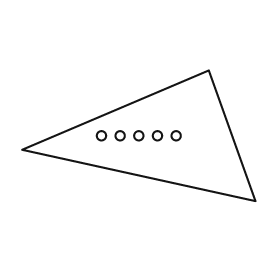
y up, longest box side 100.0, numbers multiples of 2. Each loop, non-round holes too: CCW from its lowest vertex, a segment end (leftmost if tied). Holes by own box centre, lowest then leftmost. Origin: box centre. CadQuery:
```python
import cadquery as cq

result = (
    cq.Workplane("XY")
    .moveTo(50.0, -28.0)
    .lineTo(30.0, 28.0)
    .lineTo(-50.0, -6.0)
    .close()
    .moveTo(-16.0, 0.0)
    .circle(2.0)
    .moveTo(-8.0, 0.0)
    .circle(2.0)
    .moveTo(0.0, 0.0)
    .circle(2.0)
    .moveTo(8.0, 0.0)
    .circle(2.0)
    .moveTo(16.0, 0.0)
    .circle(2.0)
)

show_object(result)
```